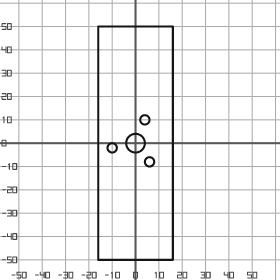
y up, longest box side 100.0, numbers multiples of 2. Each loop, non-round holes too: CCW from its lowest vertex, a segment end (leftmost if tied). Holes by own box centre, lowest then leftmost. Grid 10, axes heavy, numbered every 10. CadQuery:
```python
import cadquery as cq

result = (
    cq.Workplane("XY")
    .moveTo(-16.0, -50.0)
    .lineTo(16.0, -50.0)
    .lineTo(16.0, 50.0)
    .lineTo(-16.0, 50.0)
    .close()
    .moveTo(6.0, -8.0)
    .circle(2.0)
    .moveTo(-10.0, -2.0)
    .circle(2.0)
    .moveTo(0.0, 0.0)
    .circle(4.0)
    .moveTo(4.0, 10.0)
    .circle(2.0)
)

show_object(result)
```